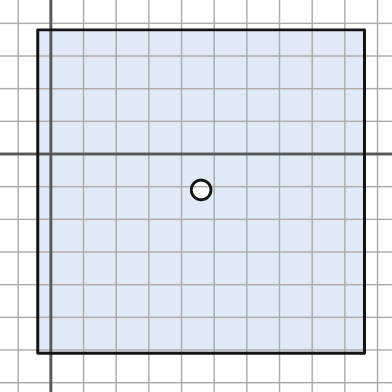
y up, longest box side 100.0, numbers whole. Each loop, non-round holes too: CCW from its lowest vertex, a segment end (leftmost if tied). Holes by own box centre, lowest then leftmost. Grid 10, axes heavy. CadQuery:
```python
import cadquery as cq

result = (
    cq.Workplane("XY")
    .moveTo(-4.0, -61.0)
    .lineTo(96.0, -61.0)
    .lineTo(96.0, 38.0)
    .lineTo(-4.0, 38.0)
    .close()
    .moveTo(46.0, -11.0)
    .circle(3.0)
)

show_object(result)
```